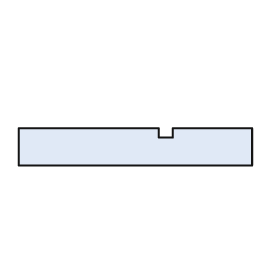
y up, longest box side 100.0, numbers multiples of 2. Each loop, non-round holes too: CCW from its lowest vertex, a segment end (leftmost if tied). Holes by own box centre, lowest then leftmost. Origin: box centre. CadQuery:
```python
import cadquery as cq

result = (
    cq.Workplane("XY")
    .moveTo(-50.0, -8.0)
    .lineTo(50.0, -8.0)
    .lineTo(50.0, 8.0)
    .lineTo(16.0, 8.0)
    .lineTo(16.0, 4.0)
    .lineTo(10.0, 4.0)
    .lineTo(10.0, 8.0)
    .lineTo(-50.0, 8.0)
    .close()
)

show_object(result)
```